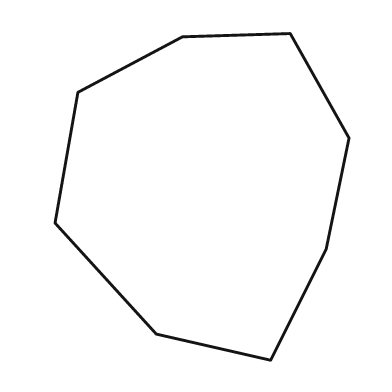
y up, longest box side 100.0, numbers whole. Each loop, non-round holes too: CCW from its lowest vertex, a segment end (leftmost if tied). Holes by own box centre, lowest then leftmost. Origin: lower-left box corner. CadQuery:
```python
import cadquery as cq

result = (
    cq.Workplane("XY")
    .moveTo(66.0, 0.0)
    .lineTo(83.0, 34.0)
    .lineTo(90.0, 68.0)
    .lineTo(72.0, 100.0)
    .lineTo(39.0, 99.0)
    .lineTo(7.0, 82.0)
    .lineTo(0.0, 42.0)
    .lineTo(31.0, 8.0)
    .close()
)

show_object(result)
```